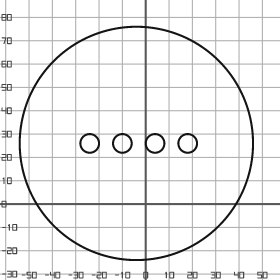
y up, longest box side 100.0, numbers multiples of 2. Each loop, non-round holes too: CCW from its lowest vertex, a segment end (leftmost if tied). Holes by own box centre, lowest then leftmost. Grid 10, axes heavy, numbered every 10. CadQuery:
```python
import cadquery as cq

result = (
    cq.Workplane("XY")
    .moveTo(-4.0, 26.0)
    .circle(50.0)
    .moveTo(-24.0, 26.0)
    .circle(4.0)
    .moveTo(-10.0, 26.0)
    .circle(4.0)
    .moveTo(4.0, 26.0)
    .circle(4.0)
    .moveTo(18.0, 26.0)
    .circle(4.0)
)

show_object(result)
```